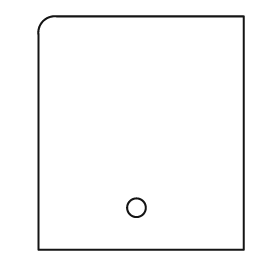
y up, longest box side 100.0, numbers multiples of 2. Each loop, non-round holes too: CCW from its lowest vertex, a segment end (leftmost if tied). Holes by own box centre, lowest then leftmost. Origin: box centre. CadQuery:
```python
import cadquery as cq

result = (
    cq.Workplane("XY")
    .moveTo(-44.0, -50.0)
    .lineTo(44.0, -50.0)
    .lineTo(44.0, 50.0)
    .lineTo(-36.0, 50.0)
    .threePointArc((-42.0, 48.0), (-44.0, 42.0))
    .close()
    .moveTo(-2.0, -32.0)
    .circle(4.0)
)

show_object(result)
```